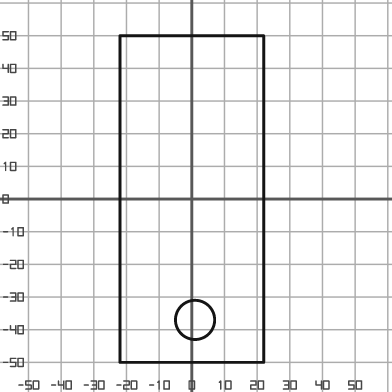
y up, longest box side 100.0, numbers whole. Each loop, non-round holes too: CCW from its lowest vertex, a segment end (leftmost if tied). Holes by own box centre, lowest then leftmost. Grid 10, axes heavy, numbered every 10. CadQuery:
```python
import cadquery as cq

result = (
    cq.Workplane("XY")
    .moveTo(-22.0, -50.0)
    .lineTo(22.0, -50.0)
    .lineTo(22.0, 50.0)
    .lineTo(-22.0, 50.0)
    .close()
    .moveTo(1.0, -37.0)
    .circle(6.0)
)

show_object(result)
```